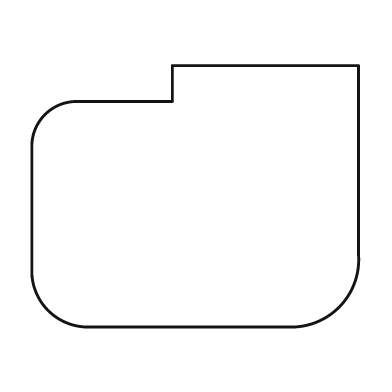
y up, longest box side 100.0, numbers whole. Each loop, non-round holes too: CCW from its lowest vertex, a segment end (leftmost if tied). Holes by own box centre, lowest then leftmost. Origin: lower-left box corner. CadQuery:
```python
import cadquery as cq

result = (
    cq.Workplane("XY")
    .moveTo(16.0, 0.0)
    .lineTo(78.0, 0.0)
    .threePointArc((94.0, 6.0), (100.0, 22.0))
    .lineTo(100.0, 80.0)
    .lineTo(43.0, 80.0)
    .lineTo(43.0, 69.0)
    .lineTo(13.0, 69.0)
    .threePointArc((4.0, 65.0), (0.0, 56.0))
    .lineTo(0.0, 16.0)
    .threePointArc((5.0, 5.0), (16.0, 0.0))
    .close()
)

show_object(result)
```